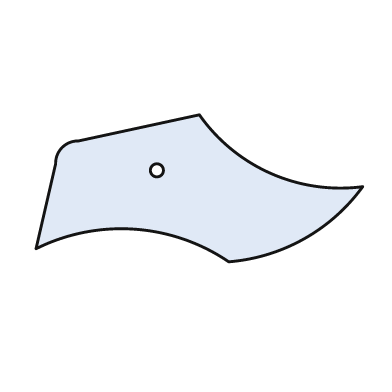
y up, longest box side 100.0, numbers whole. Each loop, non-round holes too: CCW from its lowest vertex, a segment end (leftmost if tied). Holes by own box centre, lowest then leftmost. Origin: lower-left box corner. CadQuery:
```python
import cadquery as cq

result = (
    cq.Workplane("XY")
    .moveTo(59.0, 0.0)
    .threePointArc((82.0, 7.0), (100.0, 23.0))
    .threePointArc((72.0, 27.0), (50.0, 45.0))
    .lineTo(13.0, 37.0)
    .threePointArc((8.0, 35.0), (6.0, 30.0))
    .lineTo(0.0, 4.0)
    .threePointArc((30.0, 10.0), (59.0, 0.0))
    .close()
    .moveTo(37.0, 28.0)
    .circle(2.0)
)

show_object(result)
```